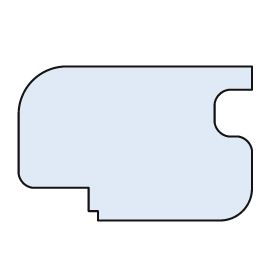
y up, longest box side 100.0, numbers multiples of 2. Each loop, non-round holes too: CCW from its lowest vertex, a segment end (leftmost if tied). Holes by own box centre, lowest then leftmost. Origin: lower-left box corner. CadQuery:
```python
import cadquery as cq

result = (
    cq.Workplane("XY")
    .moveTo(34.0, 0.0)
    .lineTo(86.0, 0.0)
    .threePointArc((96.0, 4.0), (100.0, 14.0))
    .lineTo(100.0, 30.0)
    .threePointArc((98.0, 34.0), (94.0, 36.0))
    .lineTo(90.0, 36.0)
    .threePointArc((86.0, 38.0), (84.0, 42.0))
    .lineTo(84.0, 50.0)
    .threePointArc((86.0, 54.0), (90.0, 56.0))
    .lineTo(100.0, 56.0)
    .lineTo(100.0, 66.0)
    .lineTo(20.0, 66.0)
    .threePointArc((6.0, 60.0), (0.0, 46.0))
    .lineTo(0.0, 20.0)
    .threePointArc((2.0, 16.0), (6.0, 14.0))
    .lineTo(30.0, 14.0)
    .lineTo(30.0, 4.0)
    .lineTo(34.0, 4.0)
    .close()
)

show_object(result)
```